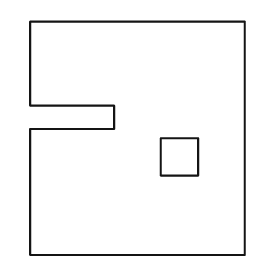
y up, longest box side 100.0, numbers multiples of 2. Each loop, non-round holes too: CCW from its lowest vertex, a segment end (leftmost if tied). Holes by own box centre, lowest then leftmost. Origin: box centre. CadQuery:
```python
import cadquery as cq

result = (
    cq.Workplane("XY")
    .moveTo(-46.0, -50.0)
    .lineTo(46.0, -50.0)
    .lineTo(46.0, 50.0)
    .lineTo(-46.0, 50.0)
    .lineTo(-46.0, 14.0)
    .lineTo(-10.0, 14.0)
    .lineTo(-10.0, 4.0)
    .lineTo(-46.0, 4.0)
    .close()
    .moveTo(10.0, -16.0)
    .lineTo(26.0, -16.0)
    .lineTo(26.0, 0.0)
    .lineTo(10.0, 0.0)
    .close()
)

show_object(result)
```